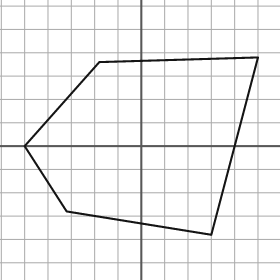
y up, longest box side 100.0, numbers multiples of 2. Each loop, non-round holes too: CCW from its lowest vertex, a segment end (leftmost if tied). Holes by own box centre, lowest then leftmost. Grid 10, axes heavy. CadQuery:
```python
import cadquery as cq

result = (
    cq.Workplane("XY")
    .moveTo(30.0, -38.0)
    .lineTo(50.0, 38.0)
    .lineTo(-18.0, 36.0)
    .lineTo(-50.0, 0.0)
    .lineTo(-32.0, -28.0)
    .close()
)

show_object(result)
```